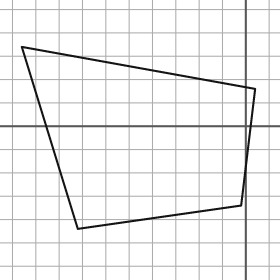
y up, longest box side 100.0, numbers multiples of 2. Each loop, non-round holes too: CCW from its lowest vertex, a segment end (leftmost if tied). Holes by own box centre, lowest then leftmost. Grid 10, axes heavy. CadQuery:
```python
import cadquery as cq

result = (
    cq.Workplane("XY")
    .moveTo(-72.0, -44.0)
    .lineTo(-2.0, -34.0)
    .lineTo(4.0, 16.0)
    .lineTo(-96.0, 34.0)
    .close()
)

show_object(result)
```